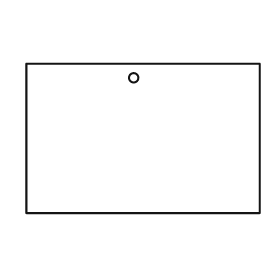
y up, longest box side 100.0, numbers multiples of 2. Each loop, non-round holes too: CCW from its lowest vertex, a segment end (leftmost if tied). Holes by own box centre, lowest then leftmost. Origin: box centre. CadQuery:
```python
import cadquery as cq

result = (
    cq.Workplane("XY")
    .moveTo(-50.0, -32.0)
    .lineTo(50.0, -32.0)
    .lineTo(50.0, 32.0)
    .lineTo(-50.0, 32.0)
    .close()
    .moveTo(-4.0, 26.0)
    .circle(2.0)
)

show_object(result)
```